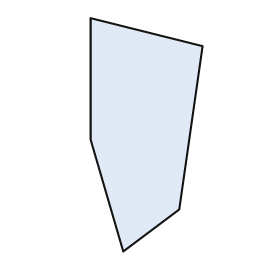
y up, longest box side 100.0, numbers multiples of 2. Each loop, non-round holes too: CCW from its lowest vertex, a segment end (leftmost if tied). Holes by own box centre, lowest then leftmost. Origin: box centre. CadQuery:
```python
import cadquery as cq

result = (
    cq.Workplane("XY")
    .moveTo(-10.0, -50.0)
    .lineTo(14.0, -32.0)
    .lineTo(24.0, 38.0)
    .lineTo(-24.0, 50.0)
    .lineTo(-24.0, -2.0)
    .close()
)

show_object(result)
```